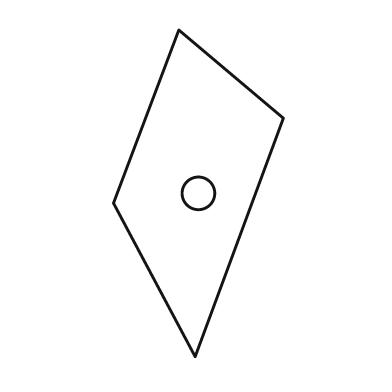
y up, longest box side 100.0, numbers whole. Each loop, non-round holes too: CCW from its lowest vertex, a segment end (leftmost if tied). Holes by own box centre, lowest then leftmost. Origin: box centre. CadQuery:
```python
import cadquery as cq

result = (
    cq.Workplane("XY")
    .moveTo(-1.0, -50.0)
    .lineTo(26.0, 23.0)
    .lineTo(-6.0, 50.0)
    .lineTo(-26.0, -3.0)
    .close()
    .moveTo(0.0, 0.0)
    .circle(5.0)
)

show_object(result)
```